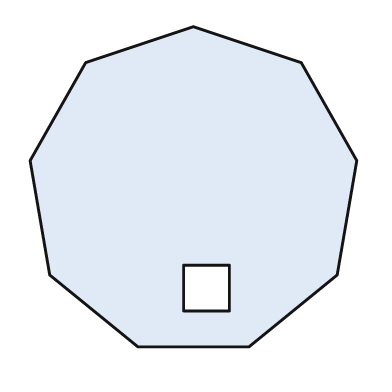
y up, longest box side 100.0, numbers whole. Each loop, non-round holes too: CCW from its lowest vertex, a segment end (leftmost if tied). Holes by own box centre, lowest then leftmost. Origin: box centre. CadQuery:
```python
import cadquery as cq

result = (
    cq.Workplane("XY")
    .moveTo(-17.0, -49.0)
    .lineTo(17.0, -49.0)
    .lineTo(44.0, -27.0)
    .lineTo(50.0, 8.0)
    .lineTo(33.0, 38.0)
    .lineTo(0.0, 49.0)
    .lineTo(-33.0, 38.0)
    .lineTo(-50.0, 8.0)
    .lineTo(-44.0, -27.0)
    .close()
    .moveTo(-3.0, -38.0)
    .lineTo(11.0, -38.0)
    .lineTo(11.0, -24.0)
    .lineTo(-3.0, -24.0)
    .close()
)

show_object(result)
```